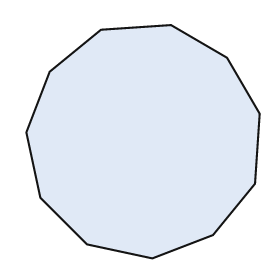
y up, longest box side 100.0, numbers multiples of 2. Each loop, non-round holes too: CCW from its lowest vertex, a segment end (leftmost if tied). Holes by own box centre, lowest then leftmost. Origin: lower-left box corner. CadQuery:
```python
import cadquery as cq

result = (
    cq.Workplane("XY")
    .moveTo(54.0, 0.0)
    .lineTo(80.0, 10.0)
    .lineTo(98.0, 32.0)
    .lineTo(100.0, 62.0)
    .lineTo(86.0, 86.0)
    .lineTo(62.0, 100.0)
    .lineTo(32.0, 98.0)
    .lineTo(10.0, 80.0)
    .lineTo(0.0, 54.0)
    .lineTo(6.0, 26.0)
    .lineTo(26.0, 6.0)
    .close()
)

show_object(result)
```